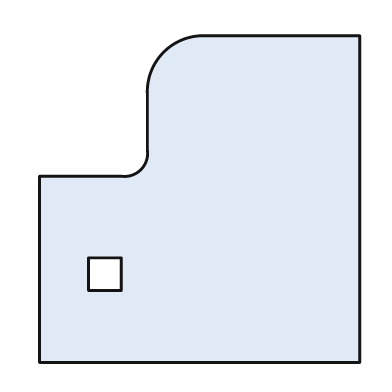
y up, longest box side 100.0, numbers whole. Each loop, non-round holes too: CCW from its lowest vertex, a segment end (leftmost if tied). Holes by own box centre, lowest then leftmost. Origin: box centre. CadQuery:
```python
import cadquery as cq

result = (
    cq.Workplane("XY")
    .moveTo(-49.0, -50.0)
    .lineTo(49.0, -50.0)
    .lineTo(49.0, 50.0)
    .lineTo(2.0, 50.0)
    .threePointArc((-11.0, 45.0), (-16.0, 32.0))
    .lineTo(-16.0, 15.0)
    .threePointArc((-18.0, 9.0), (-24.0, 7.0))
    .lineTo(-49.0, 7.0)
    .close()
    .moveTo(-34.0, -28.0)
    .lineTo(-24.0, -28.0)
    .lineTo(-24.0, -18.0)
    .lineTo(-34.0, -18.0)
    .close()
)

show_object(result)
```